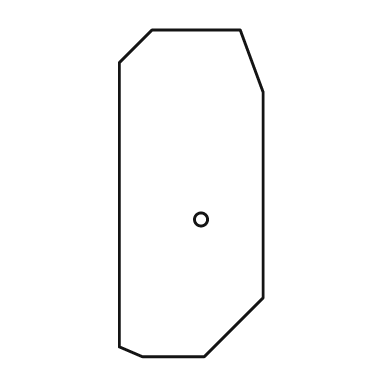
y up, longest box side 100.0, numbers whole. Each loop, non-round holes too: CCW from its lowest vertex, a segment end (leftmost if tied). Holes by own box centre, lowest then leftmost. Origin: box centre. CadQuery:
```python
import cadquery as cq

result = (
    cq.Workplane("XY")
    .moveTo(-15.0, -50.0)
    .lineTo(4.0, -50.0)
    .lineTo(22.0, -32.0)
    .lineTo(22.0, 31.0)
    .lineTo(15.0, 50.0)
    .lineTo(-12.0, 50.0)
    .lineTo(-22.0, 40.0)
    .lineTo(-22.0, -47.0)
    .close()
    .moveTo(3.0, -8.0)
    .circle(2.0)
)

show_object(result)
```